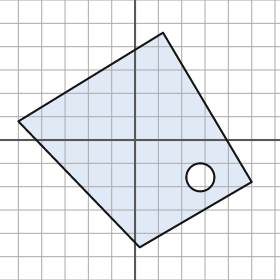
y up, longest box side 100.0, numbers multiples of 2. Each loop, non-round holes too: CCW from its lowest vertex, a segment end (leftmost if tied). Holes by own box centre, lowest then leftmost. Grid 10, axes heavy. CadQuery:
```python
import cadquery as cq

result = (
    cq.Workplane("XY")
    .moveTo(2.0, -46.0)
    .lineTo(50.0, -18.0)
    .lineTo(12.0, 46.0)
    .lineTo(-50.0, 8.0)
    .close()
    .moveTo(28.0, -16.0)
    .circle(6.0)
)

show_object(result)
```